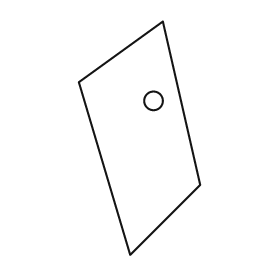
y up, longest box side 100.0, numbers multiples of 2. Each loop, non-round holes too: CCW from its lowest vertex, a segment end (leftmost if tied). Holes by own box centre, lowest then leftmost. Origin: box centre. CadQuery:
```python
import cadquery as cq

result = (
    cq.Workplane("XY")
    .moveTo(-4.0, -50.0)
    .lineTo(26.0, -20.0)
    .lineTo(10.0, 50.0)
    .lineTo(-26.0, 24.0)
    .close()
    .moveTo(6.0, 16.0)
    .circle(4.0)
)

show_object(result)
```